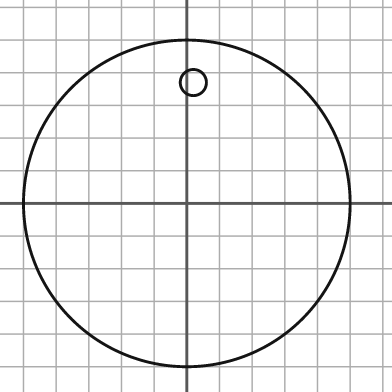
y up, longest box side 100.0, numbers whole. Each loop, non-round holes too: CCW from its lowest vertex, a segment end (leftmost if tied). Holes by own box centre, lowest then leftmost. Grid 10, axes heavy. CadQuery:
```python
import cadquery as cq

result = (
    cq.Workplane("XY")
    .moveTo(0.0, 0.0)
    .circle(50.0)
    .moveTo(2.0, 37.0)
    .circle(4.0)
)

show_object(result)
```